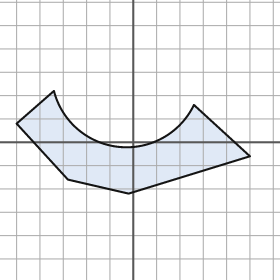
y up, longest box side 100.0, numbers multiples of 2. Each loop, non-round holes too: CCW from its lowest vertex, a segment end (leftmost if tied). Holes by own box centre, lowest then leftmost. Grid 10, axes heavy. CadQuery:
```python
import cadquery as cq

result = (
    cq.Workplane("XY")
    .moveTo(-2.0, -22.0)
    .lineTo(50.0, -6.0)
    .lineTo(26.0, 16.0)
    .threePointArc((-6.0, -2.0), (-34.0, 22.0))
    .lineTo(-50.0, 8.0)
    .lineTo(-28.0, -16.0)
    .close()
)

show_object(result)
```